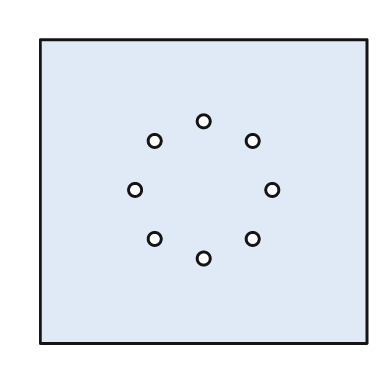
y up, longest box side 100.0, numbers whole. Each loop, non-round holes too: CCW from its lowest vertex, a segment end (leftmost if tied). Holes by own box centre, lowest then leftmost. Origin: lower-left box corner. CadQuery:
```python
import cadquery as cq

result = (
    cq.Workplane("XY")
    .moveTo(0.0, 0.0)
    .lineTo(100.0, 0.0)
    .lineTo(100.0, 93.0)
    .lineTo(0.0, 93.0)
    .close()
    .moveTo(50.0, 26.0)
    .circle(2.0)
    .moveTo(35.0, 32.0)
    .circle(2.0)
    .moveTo(65.0, 32.0)
    .circle(2.0)
    .moveTo(29.0, 47.0)
    .circle(2.0)
    .moveTo(71.0, 47.0)
    .circle(2.0)
    .moveTo(35.0, 62.0)
    .circle(2.0)
    .moveTo(65.0, 62.0)
    .circle(2.0)
    .moveTo(50.0, 68.0)
    .circle(2.0)
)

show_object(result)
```